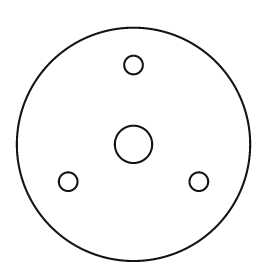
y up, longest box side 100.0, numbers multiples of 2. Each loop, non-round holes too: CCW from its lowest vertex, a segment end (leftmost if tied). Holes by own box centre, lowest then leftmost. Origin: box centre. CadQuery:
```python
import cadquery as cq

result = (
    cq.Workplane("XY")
    .moveTo(0.0, 0.0)
    .circle(50.0)
    .moveTo(-28.0, -16.0)
    .circle(4.0)
    .moveTo(28.0, -16.0)
    .circle(4.0)
    .moveTo(0.0, 0.0)
    .circle(8.0)
    .moveTo(0.0, 34.0)
    .circle(4.0)
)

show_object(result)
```